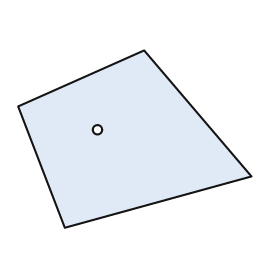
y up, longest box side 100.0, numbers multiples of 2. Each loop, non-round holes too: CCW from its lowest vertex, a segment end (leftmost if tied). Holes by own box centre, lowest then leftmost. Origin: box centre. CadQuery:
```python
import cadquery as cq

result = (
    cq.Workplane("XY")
    .moveTo(-30.0, -38.0)
    .lineTo(50.0, -16.0)
    .lineTo(4.0, 38.0)
    .lineTo(-50.0, 14.0)
    .close()
    .moveTo(-16.0, 4.0)
    .circle(2.0)
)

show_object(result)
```